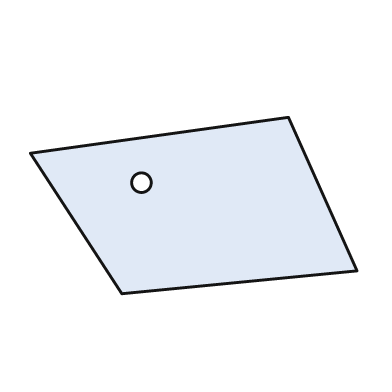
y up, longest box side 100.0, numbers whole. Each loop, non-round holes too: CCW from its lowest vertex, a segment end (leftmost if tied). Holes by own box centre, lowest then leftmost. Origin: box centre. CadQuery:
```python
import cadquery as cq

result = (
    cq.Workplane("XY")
    .moveTo(-22.0, -27.0)
    .lineTo(50.0, -20.0)
    .lineTo(29.0, 27.0)
    .lineTo(-50.0, 16.0)
    .close()
    .moveTo(-16.0, 7.0)
    .circle(3.0)
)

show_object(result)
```